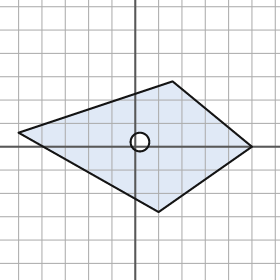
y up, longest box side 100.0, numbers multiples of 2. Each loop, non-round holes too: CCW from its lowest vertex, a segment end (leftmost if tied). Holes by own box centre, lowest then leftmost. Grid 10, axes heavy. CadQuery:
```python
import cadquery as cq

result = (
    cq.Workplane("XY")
    .moveTo(10.0, -28.0)
    .lineTo(50.0, 0.0)
    .lineTo(16.0, 28.0)
    .lineTo(-50.0, 6.0)
    .close()
    .moveTo(2.0, 2.0)
    .circle(4.0)
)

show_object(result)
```